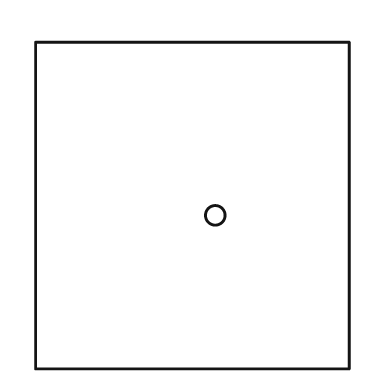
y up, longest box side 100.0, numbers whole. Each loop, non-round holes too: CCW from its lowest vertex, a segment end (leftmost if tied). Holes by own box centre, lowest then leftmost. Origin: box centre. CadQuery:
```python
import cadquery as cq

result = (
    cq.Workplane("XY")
    .moveTo(-48.0, -50.0)
    .lineTo(48.0, -50.0)
    .lineTo(48.0, 50.0)
    .lineTo(-48.0, 50.0)
    .close()
    .moveTo(7.0, -3.0)
    .circle(3.0)
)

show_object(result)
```